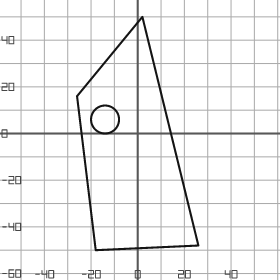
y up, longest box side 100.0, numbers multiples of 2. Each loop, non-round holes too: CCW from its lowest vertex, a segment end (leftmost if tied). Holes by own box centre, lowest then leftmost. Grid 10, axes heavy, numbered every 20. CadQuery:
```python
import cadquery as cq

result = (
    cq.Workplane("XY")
    .moveTo(-18.0, -50.0)
    .lineTo(26.0, -48.0)
    .lineTo(2.0, 50.0)
    .lineTo(-26.0, 16.0)
    .close()
    .moveTo(-14.0, 6.0)
    .circle(6.0)
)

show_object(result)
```